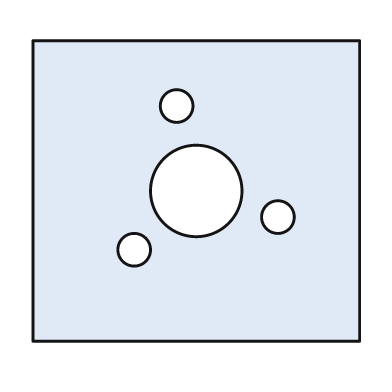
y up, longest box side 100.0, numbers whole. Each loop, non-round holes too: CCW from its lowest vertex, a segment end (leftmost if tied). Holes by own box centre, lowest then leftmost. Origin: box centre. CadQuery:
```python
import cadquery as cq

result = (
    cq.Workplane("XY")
    .moveTo(-50.0, -46.0)
    .lineTo(50.0, -46.0)
    .lineTo(50.0, 46.0)
    .lineTo(-50.0, 46.0)
    .close()
    .moveTo(-19.0, -18.0)
    .circle(5.0)
    .moveTo(25.0, -8.0)
    .circle(5.0)
    .moveTo(0.0, 0.0)
    .circle(14.0)
    .moveTo(-6.0, 26.0)
    .circle(5.0)
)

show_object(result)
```